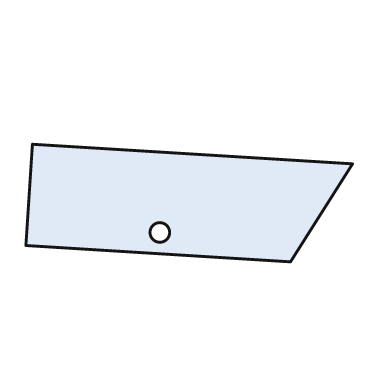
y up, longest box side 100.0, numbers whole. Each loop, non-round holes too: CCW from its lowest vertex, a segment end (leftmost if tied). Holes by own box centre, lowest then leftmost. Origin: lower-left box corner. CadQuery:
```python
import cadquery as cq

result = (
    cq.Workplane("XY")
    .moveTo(81.0, 0.0)
    .lineTo(100.0, 30.0)
    .lineTo(2.0, 36.0)
    .lineTo(0.0, 5.0)
    .close()
    .moveTo(41.0, 9.0)
    .circle(3.0)
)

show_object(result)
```